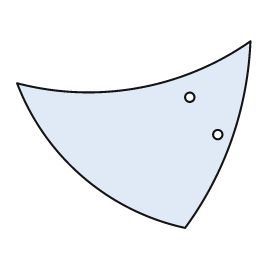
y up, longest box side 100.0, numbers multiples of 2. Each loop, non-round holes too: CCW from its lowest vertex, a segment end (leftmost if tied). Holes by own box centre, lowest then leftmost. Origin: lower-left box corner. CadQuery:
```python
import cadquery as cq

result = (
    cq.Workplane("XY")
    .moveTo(72.0, 0.0)
    .threePointArc((92.0, 38.0), (100.0, 80.0))
    .threePointArc((52.0, 60.0), (0.0, 62.0))
    .threePointArc((28.0, 22.0), (72.0, 0.0))
    .close()
    .moveTo(86.0, 40.0)
    .circle(2.0)
    .moveTo(74.0, 56.0)
    .circle(2.0)
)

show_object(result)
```